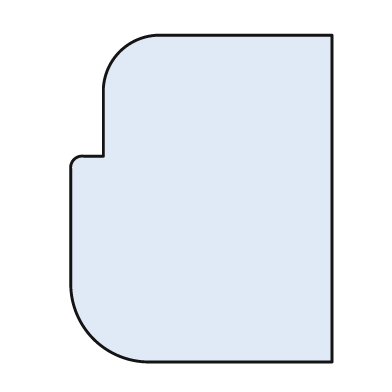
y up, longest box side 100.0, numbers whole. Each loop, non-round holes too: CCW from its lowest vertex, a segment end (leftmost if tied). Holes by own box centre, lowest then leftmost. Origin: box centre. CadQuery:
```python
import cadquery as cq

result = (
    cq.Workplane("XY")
    .moveTo(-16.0, -50.0)
    .lineTo(40.0, -50.0)
    .lineTo(40.0, 50.0)
    .lineTo(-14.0, 50.0)
    .threePointArc((-25.0, 45.0), (-30.0, 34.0))
    .lineTo(-30.0, 13.0)
    .lineTo(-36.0, 13.0)
    .threePointArc((-39.0, 12.0), (-40.0, 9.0))
    .lineTo(-40.0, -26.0)
    .threePointArc((-33.0, -43.0), (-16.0, -50.0))
    .close()
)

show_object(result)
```